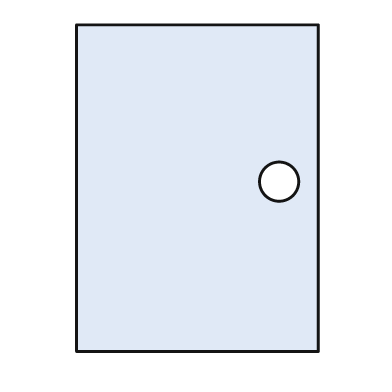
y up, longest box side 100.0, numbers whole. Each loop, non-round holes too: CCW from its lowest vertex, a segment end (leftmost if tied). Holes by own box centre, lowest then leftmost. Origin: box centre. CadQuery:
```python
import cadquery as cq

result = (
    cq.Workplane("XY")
    .moveTo(-37.0, -50.0)
    .lineTo(37.0, -50.0)
    .lineTo(37.0, 50.0)
    .lineTo(-37.0, 50.0)
    .close()
    .moveTo(25.0, 2.0)
    .circle(6.0)
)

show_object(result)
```